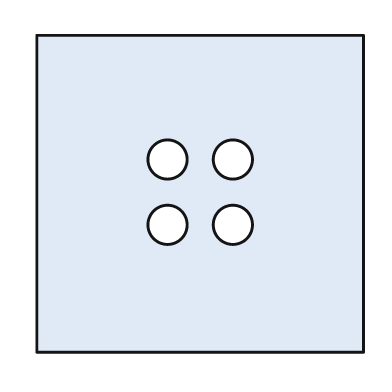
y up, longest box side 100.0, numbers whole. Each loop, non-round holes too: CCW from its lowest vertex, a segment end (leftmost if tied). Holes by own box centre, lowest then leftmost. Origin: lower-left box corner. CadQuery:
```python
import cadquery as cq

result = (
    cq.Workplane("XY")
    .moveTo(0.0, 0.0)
    .lineTo(100.0, 0.0)
    .lineTo(100.0, 97.0)
    .lineTo(0.0, 97.0)
    .close()
    .moveTo(40.0, 39.0)
    .circle(6.0)
    .moveTo(60.0, 39.0)
    .circle(6.0)
    .moveTo(40.0, 59.0)
    .circle(6.0)
    .moveTo(60.0, 59.0)
    .circle(6.0)
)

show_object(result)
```